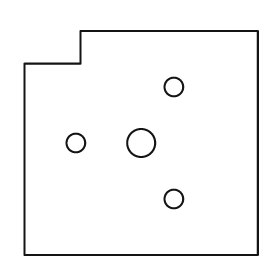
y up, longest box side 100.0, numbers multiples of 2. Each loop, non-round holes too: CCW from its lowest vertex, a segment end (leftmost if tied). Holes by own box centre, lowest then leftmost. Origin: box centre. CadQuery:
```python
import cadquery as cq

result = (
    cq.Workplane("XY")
    .moveTo(-50.0, -48.0)
    .lineTo(50.0, -48.0)
    .lineTo(50.0, 48.0)
    .lineTo(-26.0, 48.0)
    .lineTo(-26.0, 34.0)
    .lineTo(-50.0, 34.0)
    .close()
    .moveTo(14.0, -24.0)
    .circle(4.0)
    .moveTo(-28.0, 0.0)
    .circle(4.0)
    .moveTo(0.0, 0.0)
    .circle(6.0)
    .moveTo(14.0, 24.0)
    .circle(4.0)
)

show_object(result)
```